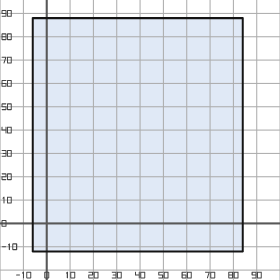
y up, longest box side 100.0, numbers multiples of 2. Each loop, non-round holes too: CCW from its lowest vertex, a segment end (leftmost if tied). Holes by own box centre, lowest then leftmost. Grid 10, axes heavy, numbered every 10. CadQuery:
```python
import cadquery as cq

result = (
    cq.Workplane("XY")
    .moveTo(-6.0, -12.0)
    .lineTo(84.0, -12.0)
    .lineTo(84.0, 88.0)
    .lineTo(-6.0, 88.0)
    .close()
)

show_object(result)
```